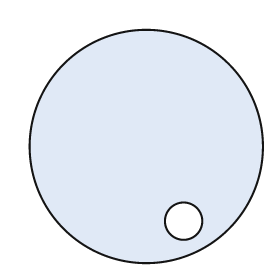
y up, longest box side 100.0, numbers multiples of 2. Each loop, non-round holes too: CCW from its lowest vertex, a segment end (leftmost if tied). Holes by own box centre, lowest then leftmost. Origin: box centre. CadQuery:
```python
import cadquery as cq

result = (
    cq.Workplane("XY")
    .moveTo(0.0, 0.0)
    .circle(50.0)
    .moveTo(16.0, -32.0)
    .circle(8.0)
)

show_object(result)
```